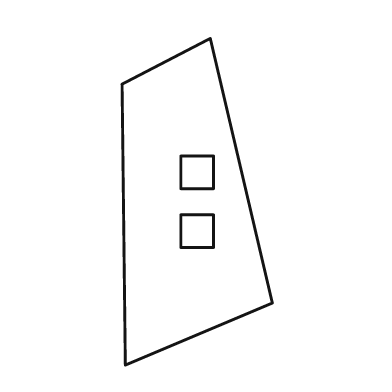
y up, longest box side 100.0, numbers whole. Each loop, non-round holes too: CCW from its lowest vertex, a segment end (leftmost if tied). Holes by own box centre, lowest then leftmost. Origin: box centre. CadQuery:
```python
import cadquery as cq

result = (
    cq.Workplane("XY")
    .moveTo(-22.0, -50.0)
    .lineTo(23.0, -31.0)
    .lineTo(4.0, 50.0)
    .lineTo(-23.0, 36.0)
    .close()
    .moveTo(-5.0, -14.0)
    .lineTo(5.0, -14.0)
    .lineTo(5.0, -4.0)
    .lineTo(-5.0, -4.0)
    .close()
    .moveTo(-5.0, 4.0)
    .lineTo(5.0, 4.0)
    .lineTo(5.0, 14.0)
    .lineTo(-5.0, 14.0)
    .close()
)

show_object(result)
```